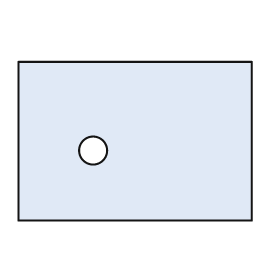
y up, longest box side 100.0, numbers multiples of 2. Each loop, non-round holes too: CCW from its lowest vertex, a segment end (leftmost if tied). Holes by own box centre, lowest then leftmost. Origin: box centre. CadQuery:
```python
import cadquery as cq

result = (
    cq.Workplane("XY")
    .moveTo(-50.0, -34.0)
    .lineTo(50.0, -34.0)
    .lineTo(50.0, 34.0)
    .lineTo(-50.0, 34.0)
    .close()
    .moveTo(-18.0, -4.0)
    .circle(6.0)
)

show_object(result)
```